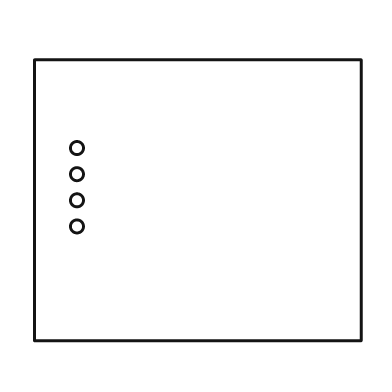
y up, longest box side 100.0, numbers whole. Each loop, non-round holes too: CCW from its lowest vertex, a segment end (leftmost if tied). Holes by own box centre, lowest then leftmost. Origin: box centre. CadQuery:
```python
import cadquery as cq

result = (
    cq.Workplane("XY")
    .moveTo(-50.0, -43.0)
    .lineTo(50.0, -43.0)
    .lineTo(50.0, 43.0)
    .lineTo(-50.0, 43.0)
    .close()
    .moveTo(-37.0, -8.0)
    .circle(2.0)
    .moveTo(-37.0, 0.0)
    .circle(2.0)
    .moveTo(-37.0, 8.0)
    .circle(2.0)
    .moveTo(-37.0, 16.0)
    .circle(2.0)
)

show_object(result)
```